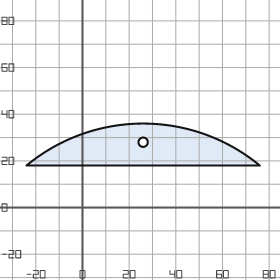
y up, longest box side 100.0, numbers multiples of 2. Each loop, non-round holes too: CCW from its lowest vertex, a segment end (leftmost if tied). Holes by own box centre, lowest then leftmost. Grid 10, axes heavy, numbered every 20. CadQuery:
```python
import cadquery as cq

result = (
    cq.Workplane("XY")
    .moveTo(-24.0, 18.0)
    .lineTo(76.0, 18.0)
    .threePointArc((26.0, 36.0), (-24.0, 18.0))
    .close()
    .moveTo(26.0, 28.0)
    .circle(2.0)
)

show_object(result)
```